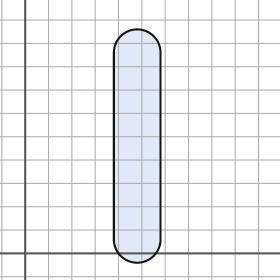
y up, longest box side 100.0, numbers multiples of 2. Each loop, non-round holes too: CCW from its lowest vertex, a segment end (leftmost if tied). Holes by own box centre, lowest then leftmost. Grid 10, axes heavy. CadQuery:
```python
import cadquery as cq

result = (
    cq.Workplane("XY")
    .moveTo(38.0, 6.0)
    .threePointArc((48.0, -4.0), (58.0, 6.0))
    .lineTo(58.0, 86.0)
    .threePointArc((48.0, 96.0), (38.0, 86.0))
    .close()
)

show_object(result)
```